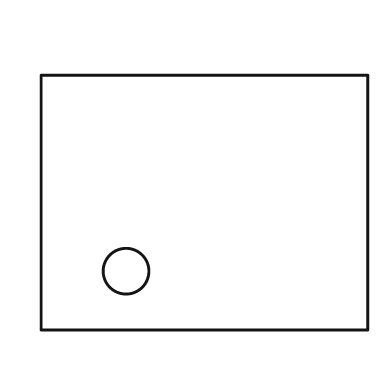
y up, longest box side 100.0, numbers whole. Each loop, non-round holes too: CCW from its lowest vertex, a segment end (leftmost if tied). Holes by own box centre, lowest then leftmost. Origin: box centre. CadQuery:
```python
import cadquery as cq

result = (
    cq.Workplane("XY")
    .moveTo(-50.0, -39.0)
    .lineTo(50.0, -39.0)
    .lineTo(50.0, 39.0)
    .lineTo(-50.0, 39.0)
    .close()
    .moveTo(-24.0, -21.0)
    .circle(7.0)
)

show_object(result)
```